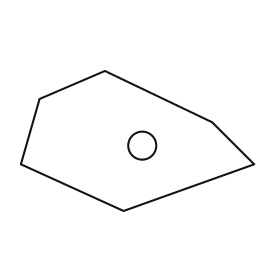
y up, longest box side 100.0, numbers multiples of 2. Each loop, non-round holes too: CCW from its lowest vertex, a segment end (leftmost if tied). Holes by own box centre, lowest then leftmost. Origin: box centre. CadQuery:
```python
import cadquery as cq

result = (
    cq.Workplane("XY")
    .moveTo(-6.0, -30.0)
    .lineTo(50.0, -10.0)
    .lineTo(32.0, 8.0)
    .lineTo(-14.0, 30.0)
    .lineTo(-42.0, 18.0)
    .lineTo(-50.0, -10.0)
    .close()
    .moveTo(2.0, -2.0)
    .circle(6.0)
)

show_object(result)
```